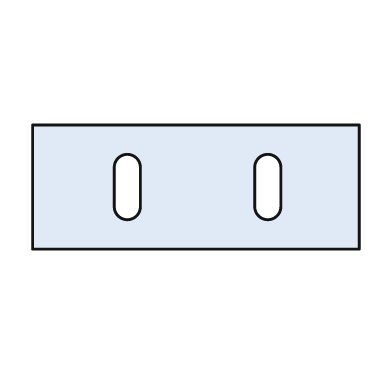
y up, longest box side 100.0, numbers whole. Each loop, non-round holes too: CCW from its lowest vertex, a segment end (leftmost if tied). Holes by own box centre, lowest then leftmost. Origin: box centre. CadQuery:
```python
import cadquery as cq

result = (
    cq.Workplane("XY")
    .moveTo(-50.0, -19.0)
    .lineTo(50.0, -19.0)
    .lineTo(50.0, 19.0)
    .lineTo(-50.0, 19.0)
    .close()
    .moveTo(-25.0, -6.0)
    .threePointArc((-21.0, -10.0), (-17.0, -6.0))
    .lineTo(-17.0, 6.0)
    .threePointArc((-21.0, 10.0), (-25.0, 6.0))
    .close()
    .moveTo(18.0, -6.0)
    .threePointArc((22.0, -10.0), (26.0, -6.0))
    .lineTo(26.0, 6.0)
    .threePointArc((22.0, 10.0), (18.0, 6.0))
    .close()
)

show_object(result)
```